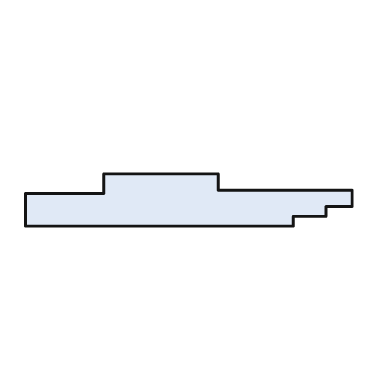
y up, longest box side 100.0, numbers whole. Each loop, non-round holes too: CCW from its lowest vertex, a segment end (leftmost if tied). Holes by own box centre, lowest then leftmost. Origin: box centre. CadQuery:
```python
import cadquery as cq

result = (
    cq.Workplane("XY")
    .moveTo(-50.0, -8.0)
    .lineTo(32.0, -8.0)
    .lineTo(32.0, -5.0)
    .lineTo(42.0, -5.0)
    .lineTo(42.0, -2.0)
    .lineTo(50.0, -2.0)
    .lineTo(50.0, 3.0)
    .lineTo(9.0, 3.0)
    .lineTo(9.0, 8.0)
    .lineTo(-26.0, 8.0)
    .lineTo(-26.0, 2.0)
    .lineTo(-50.0, 2.0)
    .close()
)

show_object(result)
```